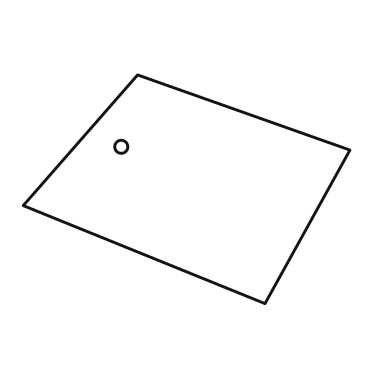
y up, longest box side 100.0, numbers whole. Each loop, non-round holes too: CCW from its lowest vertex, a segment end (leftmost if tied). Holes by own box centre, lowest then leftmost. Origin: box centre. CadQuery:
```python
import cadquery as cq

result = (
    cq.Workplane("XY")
    .moveTo(24.0, -35.0)
    .lineTo(50.0, 12.0)
    .lineTo(-15.0, 35.0)
    .lineTo(-50.0, -5.0)
    .close()
    .moveTo(-20.0, 13.0)
    .circle(2.0)
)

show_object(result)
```